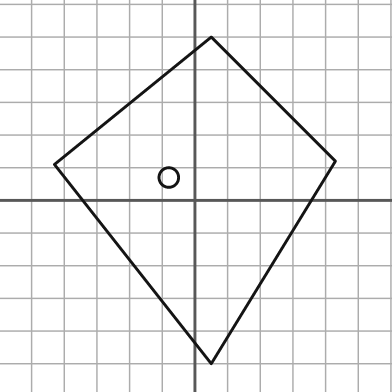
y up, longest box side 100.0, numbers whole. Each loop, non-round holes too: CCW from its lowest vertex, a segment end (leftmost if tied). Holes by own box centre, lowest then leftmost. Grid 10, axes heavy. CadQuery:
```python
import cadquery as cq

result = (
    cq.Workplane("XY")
    .moveTo(5.0, -50.0)
    .lineTo(43.0, 12.0)
    .lineTo(5.0, 50.0)
    .lineTo(-43.0, 11.0)
    .close()
    .moveTo(-8.0, 7.0)
    .circle(3.0)
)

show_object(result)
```